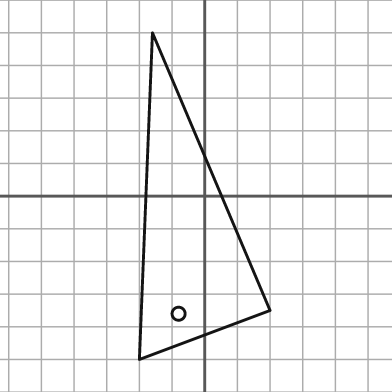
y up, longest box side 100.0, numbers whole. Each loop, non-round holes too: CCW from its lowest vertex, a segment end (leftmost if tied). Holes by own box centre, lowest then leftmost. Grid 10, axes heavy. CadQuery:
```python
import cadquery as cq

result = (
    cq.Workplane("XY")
    .moveTo(-20.0, -50.0)
    .lineTo(20.0, -35.0)
    .lineTo(-16.0, 50.0)
    .close()
    .moveTo(-8.0, -36.0)
    .circle(2.0)
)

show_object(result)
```